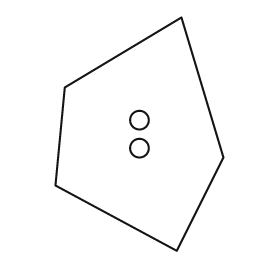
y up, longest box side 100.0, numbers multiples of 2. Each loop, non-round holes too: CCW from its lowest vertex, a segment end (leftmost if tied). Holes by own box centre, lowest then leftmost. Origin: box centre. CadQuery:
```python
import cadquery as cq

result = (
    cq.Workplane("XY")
    .moveTo(16.0, -50.0)
    .lineTo(36.0, -10.0)
    .lineTo(18.0, 50.0)
    .lineTo(-32.0, 20.0)
    .lineTo(-36.0, -22.0)
    .close()
    .moveTo(0.0, -6.0)
    .circle(4.0)
    .moveTo(0.0, 6.0)
    .circle(4.0)
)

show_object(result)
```